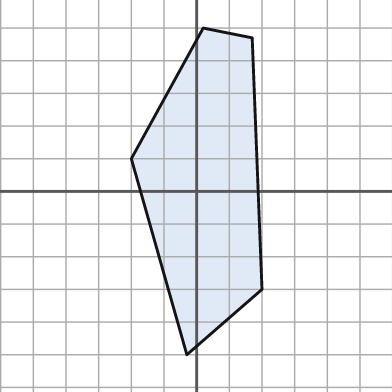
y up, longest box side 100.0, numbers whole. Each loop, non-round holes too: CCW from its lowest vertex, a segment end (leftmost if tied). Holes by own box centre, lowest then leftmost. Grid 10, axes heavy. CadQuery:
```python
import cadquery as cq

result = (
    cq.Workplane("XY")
    .moveTo(-3.0, -50.0)
    .lineTo(20.0, -30.0)
    .lineTo(17.0, 47.0)
    .lineTo(2.0, 50.0)
    .lineTo(-20.0, 10.0)
    .close()
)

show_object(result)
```